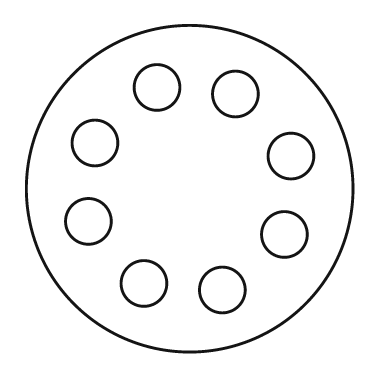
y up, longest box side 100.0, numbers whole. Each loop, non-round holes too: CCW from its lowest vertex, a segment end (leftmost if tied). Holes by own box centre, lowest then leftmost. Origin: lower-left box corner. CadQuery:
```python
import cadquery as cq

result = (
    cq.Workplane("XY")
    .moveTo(50.0, 50.0)
    .circle(50.0)
    .moveTo(60.0, 19.0)
    .circle(7.0)
    .moveTo(36.0, 21.0)
    .circle(7.0)
    .moveTo(79.0, 36.0)
    .circle(7.0)
    .moveTo(19.0, 40.0)
    .circle(7.0)
    .moveTo(81.0, 60.0)
    .circle(7.0)
    .moveTo(21.0, 64.0)
    .circle(7.0)
    .moveTo(64.0, 79.0)
    .circle(7.0)
    .moveTo(40.0, 81.0)
    .circle(7.0)
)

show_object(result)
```